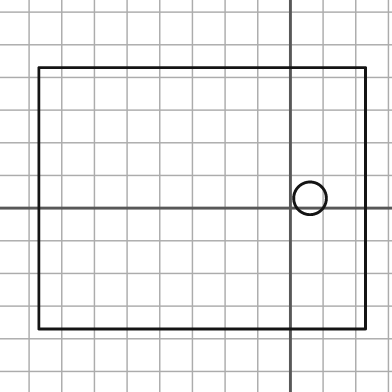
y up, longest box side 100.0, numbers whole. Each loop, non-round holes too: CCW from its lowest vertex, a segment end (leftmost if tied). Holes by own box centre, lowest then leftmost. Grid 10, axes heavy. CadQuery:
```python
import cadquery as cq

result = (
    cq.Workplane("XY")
    .moveTo(-77.0, -37.0)
    .lineTo(23.0, -37.0)
    .lineTo(23.0, 43.0)
    .lineTo(-77.0, 43.0)
    .close()
    .moveTo(6.0, 3.0)
    .circle(5.0)
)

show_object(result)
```